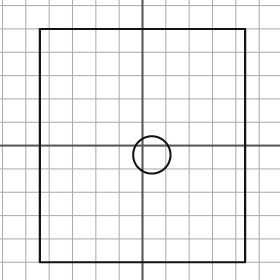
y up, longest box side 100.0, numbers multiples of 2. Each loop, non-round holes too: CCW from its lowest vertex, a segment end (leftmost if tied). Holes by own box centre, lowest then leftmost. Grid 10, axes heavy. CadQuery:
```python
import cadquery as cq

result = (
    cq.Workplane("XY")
    .moveTo(-44.0, -50.0)
    .lineTo(44.0, -50.0)
    .lineTo(44.0, 50.0)
    .lineTo(-44.0, 50.0)
    .close()
    .moveTo(4.0, -4.0)
    .circle(8.0)
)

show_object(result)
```